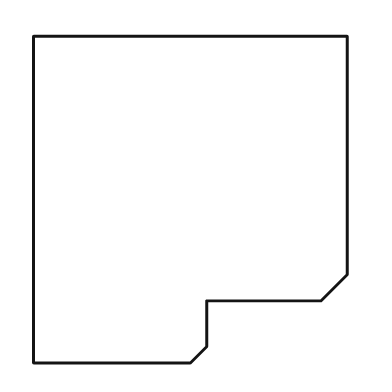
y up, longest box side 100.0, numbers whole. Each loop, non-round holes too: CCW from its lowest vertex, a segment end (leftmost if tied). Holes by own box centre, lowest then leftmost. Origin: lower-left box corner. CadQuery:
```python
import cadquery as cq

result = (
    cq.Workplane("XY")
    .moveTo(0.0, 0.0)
    .lineTo(48.0, 0.0)
    .lineTo(53.0, 5.0)
    .lineTo(53.0, 19.0)
    .lineTo(88.0, 19.0)
    .lineTo(96.0, 27.0)
    .lineTo(96.0, 100.0)
    .lineTo(0.0, 100.0)
    .close()
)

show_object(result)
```